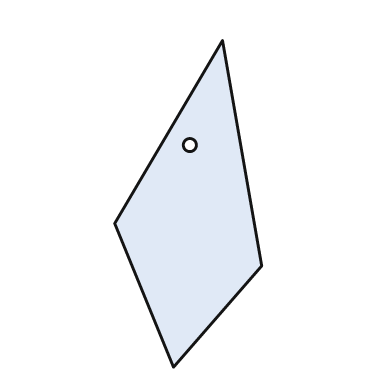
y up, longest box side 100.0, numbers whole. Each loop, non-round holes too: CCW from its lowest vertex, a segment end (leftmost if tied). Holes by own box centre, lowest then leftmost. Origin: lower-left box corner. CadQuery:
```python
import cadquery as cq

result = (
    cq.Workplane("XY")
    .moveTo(18.0, 0.0)
    .lineTo(45.0, 31.0)
    .lineTo(33.0, 100.0)
    .lineTo(0.0, 44.0)
    .close()
    .moveTo(23.0, 68.0)
    .circle(2.0)
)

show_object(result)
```